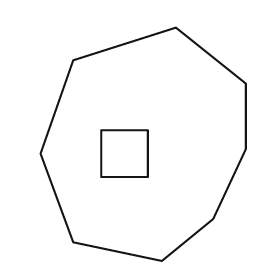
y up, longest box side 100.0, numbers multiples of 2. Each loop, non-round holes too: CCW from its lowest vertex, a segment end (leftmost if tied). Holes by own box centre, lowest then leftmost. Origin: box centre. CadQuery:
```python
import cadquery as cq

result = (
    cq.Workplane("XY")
    .moveTo(8.0, -50.0)
    .lineTo(30.0, -32.0)
    .lineTo(44.0, -2.0)
    .lineTo(44.0, 26.0)
    .lineTo(14.0, 50.0)
    .lineTo(-30.0, 36.0)
    .lineTo(-44.0, -4.0)
    .lineTo(-30.0, -42.0)
    .close()
    .moveTo(-18.0, -14.0)
    .lineTo(2.0, -14.0)
    .lineTo(2.0, 6.0)
    .lineTo(-18.0, 6.0)
    .close()
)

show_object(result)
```